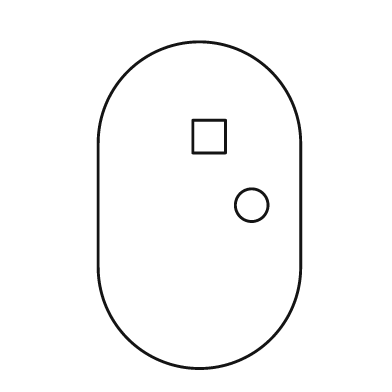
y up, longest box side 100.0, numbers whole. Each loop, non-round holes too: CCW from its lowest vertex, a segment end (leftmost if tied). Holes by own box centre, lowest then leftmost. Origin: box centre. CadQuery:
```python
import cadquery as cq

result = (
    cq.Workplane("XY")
    .moveTo(-31.0, -19.0)
    .threePointArc((0.0, -50.0), (31.0, -19.0))
    .lineTo(31.0, 19.0)
    .threePointArc((0.0, 50.0), (-31.0, 19.0))
    .close()
    .moveTo(16.0, 0.0)
    .circle(5.0)
    .moveTo(-2.0, 16.0)
    .lineTo(8.0, 16.0)
    .lineTo(8.0, 26.0)
    .lineTo(-2.0, 26.0)
    .close()
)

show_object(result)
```